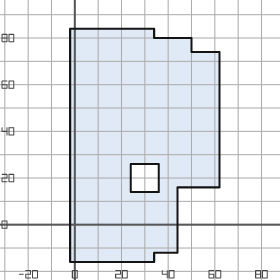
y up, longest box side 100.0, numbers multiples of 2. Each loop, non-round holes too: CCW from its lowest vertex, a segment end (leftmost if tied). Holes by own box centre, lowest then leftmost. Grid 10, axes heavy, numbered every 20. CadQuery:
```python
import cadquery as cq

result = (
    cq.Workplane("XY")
    .moveTo(-2.0, -16.0)
    .lineTo(34.0, -16.0)
    .lineTo(34.0, -12.0)
    .lineTo(44.0, -12.0)
    .lineTo(44.0, 16.0)
    .lineTo(62.0, 16.0)
    .lineTo(62.0, 74.0)
    .lineTo(50.0, 74.0)
    .lineTo(50.0, 80.0)
    .lineTo(34.0, 80.0)
    .lineTo(34.0, 84.0)
    .lineTo(-2.0, 84.0)
    .close()
    .moveTo(24.0, 14.0)
    .lineTo(36.0, 14.0)
    .lineTo(36.0, 26.0)
    .lineTo(24.0, 26.0)
    .close()
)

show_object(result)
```